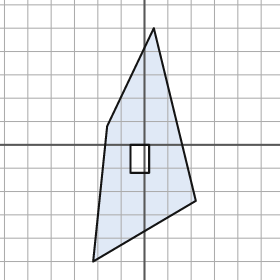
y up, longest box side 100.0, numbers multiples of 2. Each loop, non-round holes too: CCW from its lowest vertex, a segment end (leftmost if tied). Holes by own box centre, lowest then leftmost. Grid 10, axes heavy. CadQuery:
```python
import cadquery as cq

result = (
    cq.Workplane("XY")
    .moveTo(-22.0, -50.0)
    .lineTo(22.0, -24.0)
    .lineTo(4.0, 50.0)
    .lineTo(-16.0, 8.0)
    .close()
    .moveTo(-6.0, -12.0)
    .lineTo(2.0, -12.0)
    .lineTo(2.0, 0.0)
    .lineTo(-6.0, 0.0)
    .close()
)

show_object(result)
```